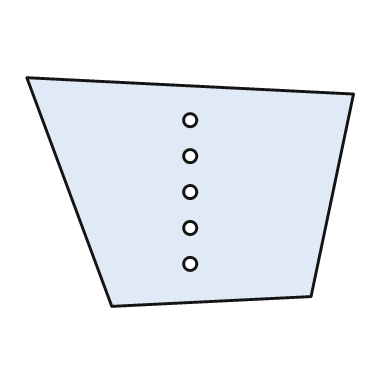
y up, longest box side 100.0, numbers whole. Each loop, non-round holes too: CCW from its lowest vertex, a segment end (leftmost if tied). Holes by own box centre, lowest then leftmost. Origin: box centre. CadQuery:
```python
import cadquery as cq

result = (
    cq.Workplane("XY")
    .moveTo(-24.0, -35.0)
    .lineTo(37.0, -32.0)
    .lineTo(50.0, 30.0)
    .lineTo(-50.0, 35.0)
    .close()
    .moveTo(0.0, -22.0)
    .circle(2.0)
    .moveTo(0.0, -11.0)
    .circle(2.0)
    .moveTo(0.0, 0.0)
    .circle(2.0)
    .moveTo(0.0, 11.0)
    .circle(2.0)
    .moveTo(0.0, 22.0)
    .circle(2.0)
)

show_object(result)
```